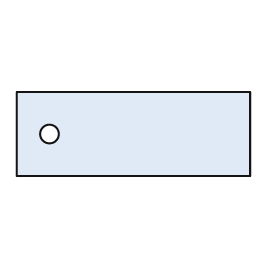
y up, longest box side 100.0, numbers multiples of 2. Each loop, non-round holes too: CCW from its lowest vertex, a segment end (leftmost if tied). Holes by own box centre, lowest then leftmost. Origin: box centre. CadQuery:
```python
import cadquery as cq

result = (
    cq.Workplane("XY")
    .moveTo(-50.0, -18.0)
    .lineTo(50.0, -18.0)
    .lineTo(50.0, 18.0)
    .lineTo(-50.0, 18.0)
    .close()
    .moveTo(-36.0, 0.0)
    .circle(4.0)
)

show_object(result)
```